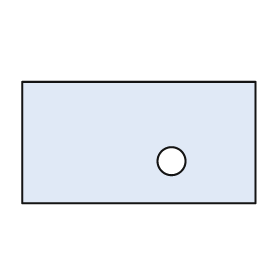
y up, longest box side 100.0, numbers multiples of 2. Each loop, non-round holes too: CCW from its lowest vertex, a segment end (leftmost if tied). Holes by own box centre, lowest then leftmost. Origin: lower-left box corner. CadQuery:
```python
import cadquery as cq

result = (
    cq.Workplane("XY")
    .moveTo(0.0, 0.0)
    .lineTo(100.0, 0.0)
    .lineTo(100.0, 52.0)
    .lineTo(0.0, 52.0)
    .close()
    .moveTo(64.0, 18.0)
    .circle(6.0)
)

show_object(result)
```